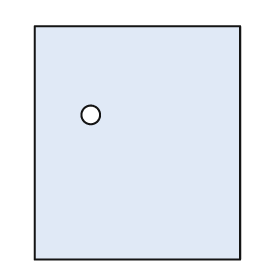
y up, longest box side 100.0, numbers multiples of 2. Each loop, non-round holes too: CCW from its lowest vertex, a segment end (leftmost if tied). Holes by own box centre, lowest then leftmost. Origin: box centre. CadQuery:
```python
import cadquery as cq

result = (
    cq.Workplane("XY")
    .moveTo(-44.0, -50.0)
    .lineTo(44.0, -50.0)
    .lineTo(44.0, 50.0)
    .lineTo(-44.0, 50.0)
    .close()
    .moveTo(-20.0, 12.0)
    .circle(4.0)
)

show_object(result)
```